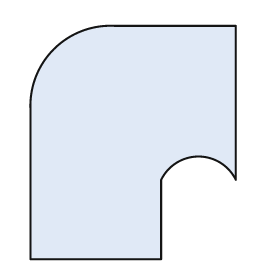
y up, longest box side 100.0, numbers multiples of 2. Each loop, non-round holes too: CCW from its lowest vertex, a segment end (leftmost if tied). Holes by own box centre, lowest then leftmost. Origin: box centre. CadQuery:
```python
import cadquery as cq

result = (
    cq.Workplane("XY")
    .moveTo(-44.0, -50.0)
    .lineTo(12.0, -50.0)
    .lineTo(12.0, -16.0)
    .threePointArc((28.0, -6.0), (44.0, -16.0))
    .lineTo(44.0, 50.0)
    .lineTo(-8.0, 50.0)
    .threePointArc((-34.0, 40.0), (-44.0, 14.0))
    .close()
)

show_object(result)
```